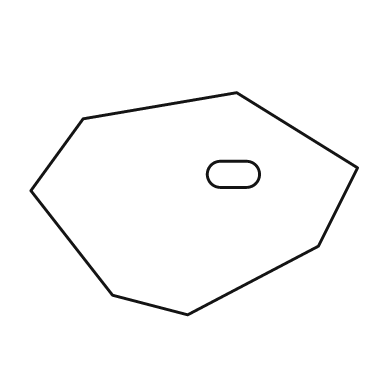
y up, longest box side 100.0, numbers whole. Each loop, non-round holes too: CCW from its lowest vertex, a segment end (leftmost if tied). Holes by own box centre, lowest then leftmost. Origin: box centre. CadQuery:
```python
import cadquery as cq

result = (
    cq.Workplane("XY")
    .moveTo(-2.0, -34.0)
    .lineTo(38.0, -13.0)
    .lineTo(50.0, 11.0)
    .lineTo(13.0, 34.0)
    .lineTo(-34.0, 26.0)
    .lineTo(-50.0, 4.0)
    .lineTo(-25.0, -28.0)
    .close()
    .moveTo(8.0, 5.0)
    .lineTo(16.0, 5.0)
    .threePointArc((20.0, 9.0), (16.0, 13.0))
    .lineTo(8.0, 13.0)
    .threePointArc((4.0, 9.0), (8.0, 5.0))
    .close()
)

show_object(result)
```